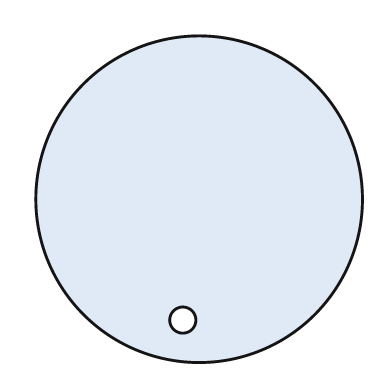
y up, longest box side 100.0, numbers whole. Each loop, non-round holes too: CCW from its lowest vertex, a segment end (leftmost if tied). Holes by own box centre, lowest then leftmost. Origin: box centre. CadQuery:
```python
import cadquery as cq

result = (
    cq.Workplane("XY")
    .moveTo(0.0, 0.0)
    .circle(50.0)
    .moveTo(-5.0, -37.0)
    .circle(4.0)
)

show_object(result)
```